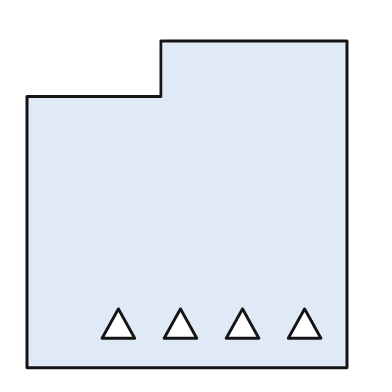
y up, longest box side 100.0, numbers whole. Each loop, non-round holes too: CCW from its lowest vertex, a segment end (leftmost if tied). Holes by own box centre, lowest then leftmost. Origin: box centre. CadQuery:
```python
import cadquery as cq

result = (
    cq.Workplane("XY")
    .moveTo(-49.0, -50.0)
    .lineTo(49.0, -50.0)
    .lineTo(49.0, 50.0)
    .lineTo(-8.0, 50.0)
    .lineTo(-8.0, 33.0)
    .lineTo(-49.0, 33.0)
    .close()
    .moveTo(-26.0, -41.0)
    .lineTo(-16.0, -41.0)
    .lineTo(-21.0, -32.0)
    .close()
    .moveTo(-7.0, -41.0)
    .lineTo(3.0, -41.0)
    .lineTo(-2.0, -32.0)
    .close()
    .moveTo(12.0, -41.0)
    .lineTo(22.0, -41.0)
    .lineTo(17.0, -32.0)
    .close()
    .moveTo(31.0, -41.0)
    .lineTo(41.0, -41.0)
    .lineTo(36.0, -32.0)
    .close()
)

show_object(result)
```